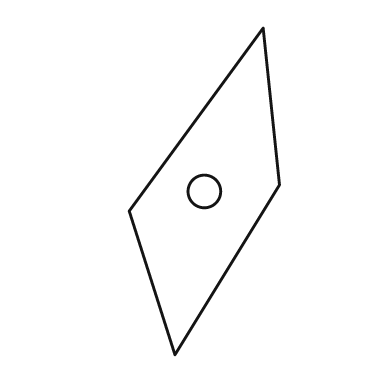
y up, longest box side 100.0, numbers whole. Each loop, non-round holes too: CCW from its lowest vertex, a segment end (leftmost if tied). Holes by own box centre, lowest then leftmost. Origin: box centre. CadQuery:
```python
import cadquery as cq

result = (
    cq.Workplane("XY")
    .moveTo(-9.0, -50.0)
    .lineTo(23.0, 2.0)
    .lineTo(18.0, 50.0)
    .lineTo(-23.0, -6.0)
    .close()
    .moveTo(0.0, 0.0)
    .circle(5.0)
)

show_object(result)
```